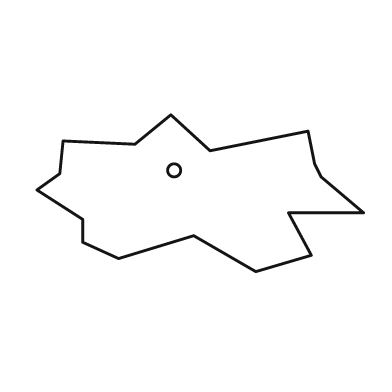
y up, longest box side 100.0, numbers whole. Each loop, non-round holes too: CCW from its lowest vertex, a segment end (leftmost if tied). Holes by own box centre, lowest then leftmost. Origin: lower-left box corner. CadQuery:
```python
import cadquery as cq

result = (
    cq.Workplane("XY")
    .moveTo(67.0, 0.0)
    .lineTo(84.0, 5.0)
    .lineTo(77.0, 18.0)
    .lineTo(100.0, 18.0)
    .lineTo(87.0, 29.0)
    .lineTo(85.0, 33.0)
    .lineTo(83.0, 43.0)
    .lineTo(53.0, 37.0)
    .lineTo(41.0, 48.0)
    .lineTo(30.0, 39.0)
    .lineTo(8.0, 40.0)
    .lineTo(7.0, 30.0)
    .lineTo(0.0, 25.0)
    .lineTo(14.0, 16.0)
    .lineTo(14.0, 9.0)
    .lineTo(25.0, 4.0)
    .lineTo(48.0, 11.0)
    .close()
    .moveTo(42.0, 31.0)
    .circle(2.0)
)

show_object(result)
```